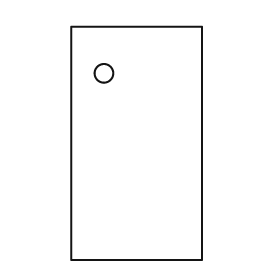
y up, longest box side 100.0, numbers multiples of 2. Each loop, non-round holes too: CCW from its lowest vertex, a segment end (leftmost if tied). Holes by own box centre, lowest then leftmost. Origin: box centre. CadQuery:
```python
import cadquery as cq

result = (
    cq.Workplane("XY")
    .moveTo(-28.0, -50.0)
    .lineTo(28.0, -50.0)
    .lineTo(28.0, 50.0)
    .lineTo(-28.0, 50.0)
    .close()
    .moveTo(-14.0, 30.0)
    .circle(4.0)
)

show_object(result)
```